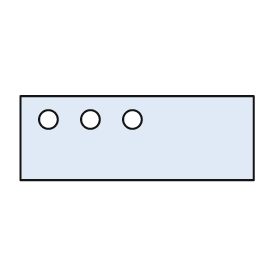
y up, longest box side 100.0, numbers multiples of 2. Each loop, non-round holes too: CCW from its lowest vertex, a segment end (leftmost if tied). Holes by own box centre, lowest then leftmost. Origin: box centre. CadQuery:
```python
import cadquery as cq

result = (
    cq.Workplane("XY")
    .moveTo(-50.0, -18.0)
    .lineTo(50.0, -18.0)
    .lineTo(50.0, 18.0)
    .lineTo(-50.0, 18.0)
    .close()
    .moveTo(-38.0, 8.0)
    .circle(4.0)
    .moveTo(-20.0, 8.0)
    .circle(4.0)
    .moveTo(-2.0, 8.0)
    .circle(4.0)
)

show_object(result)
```